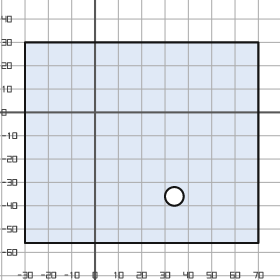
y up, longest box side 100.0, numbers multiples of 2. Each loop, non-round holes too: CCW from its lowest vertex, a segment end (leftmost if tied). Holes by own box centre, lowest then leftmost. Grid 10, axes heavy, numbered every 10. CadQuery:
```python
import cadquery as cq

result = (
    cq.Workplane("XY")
    .moveTo(-30.0, -56.0)
    .lineTo(70.0, -56.0)
    .lineTo(70.0, 30.0)
    .lineTo(-30.0, 30.0)
    .close()
    .moveTo(34.0, -36.0)
    .circle(4.0)
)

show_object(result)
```